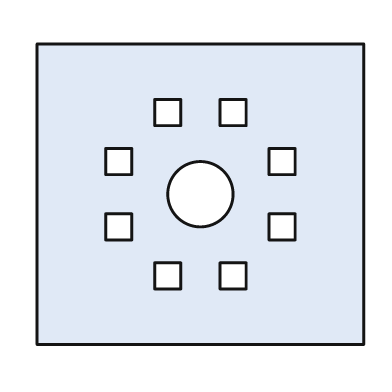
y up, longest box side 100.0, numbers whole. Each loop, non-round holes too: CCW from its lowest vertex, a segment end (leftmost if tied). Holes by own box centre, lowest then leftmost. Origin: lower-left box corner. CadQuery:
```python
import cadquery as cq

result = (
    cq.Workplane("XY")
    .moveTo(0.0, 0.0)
    .lineTo(100.0, 0.0)
    .lineTo(100.0, 92.0)
    .lineTo(0.0, 92.0)
    .close()
    .moveTo(36.0, 17.0)
    .lineTo(44.0, 17.0)
    .lineTo(44.0, 25.0)
    .lineTo(36.0, 25.0)
    .close()
    .moveTo(56.0, 17.0)
    .lineTo(64.0, 17.0)
    .lineTo(64.0, 25.0)
    .lineTo(56.0, 25.0)
    .close()
    .moveTo(21.0, 32.0)
    .lineTo(29.0, 32.0)
    .lineTo(29.0, 40.0)
    .lineTo(21.0, 40.0)
    .close()
    .moveTo(71.0, 32.0)
    .lineTo(79.0, 32.0)
    .lineTo(79.0, 40.0)
    .lineTo(71.0, 40.0)
    .close()
    .moveTo(50.0, 46.0)
    .circle(10.0)
    .moveTo(21.0, 52.0)
    .lineTo(29.0, 52.0)
    .lineTo(29.0, 60.0)
    .lineTo(21.0, 60.0)
    .close()
    .moveTo(71.0, 52.0)
    .lineTo(79.0, 52.0)
    .lineTo(79.0, 60.0)
    .lineTo(71.0, 60.0)
    .close()
    .moveTo(36.0, 67.0)
    .lineTo(44.0, 67.0)
    .lineTo(44.0, 75.0)
    .lineTo(36.0, 75.0)
    .close()
    .moveTo(56.0, 67.0)
    .lineTo(64.0, 67.0)
    .lineTo(64.0, 75.0)
    .lineTo(56.0, 75.0)
    .close()
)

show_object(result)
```